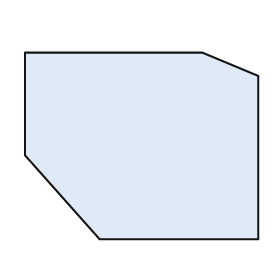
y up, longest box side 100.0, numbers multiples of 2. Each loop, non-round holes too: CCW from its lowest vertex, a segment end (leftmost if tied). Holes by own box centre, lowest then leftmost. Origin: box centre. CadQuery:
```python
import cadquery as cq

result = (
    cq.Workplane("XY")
    .moveTo(-18.0, -40.0)
    .lineTo(50.0, -40.0)
    .lineTo(50.0, 30.0)
    .lineTo(26.0, 40.0)
    .lineTo(-50.0, 40.0)
    .lineTo(-50.0, -4.0)
    .close()
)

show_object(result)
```